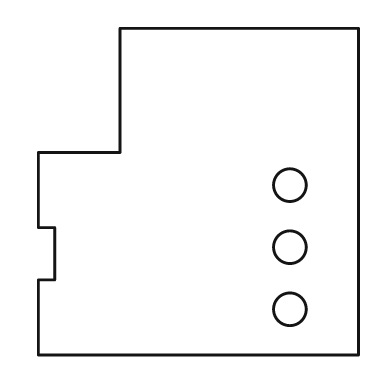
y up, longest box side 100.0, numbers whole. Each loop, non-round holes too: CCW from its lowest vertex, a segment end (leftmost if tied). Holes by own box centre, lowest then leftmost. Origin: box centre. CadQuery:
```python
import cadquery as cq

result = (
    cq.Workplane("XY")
    .moveTo(-49.0, -50.0)
    .lineTo(49.0, -50.0)
    .lineTo(49.0, 50.0)
    .lineTo(-24.0, 50.0)
    .lineTo(-24.0, 12.0)
    .lineTo(-49.0, 12.0)
    .lineTo(-49.0, -11.0)
    .lineTo(-44.0, -11.0)
    .lineTo(-44.0, -27.0)
    .lineTo(-49.0, -27.0)
    .close()
    .moveTo(28.0, -36.0)
    .circle(5.0)
    .moveTo(28.0, -17.0)
    .circle(5.0)
    .moveTo(28.0, 2.0)
    .circle(5.0)
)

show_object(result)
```